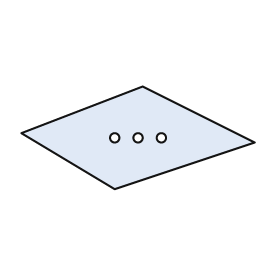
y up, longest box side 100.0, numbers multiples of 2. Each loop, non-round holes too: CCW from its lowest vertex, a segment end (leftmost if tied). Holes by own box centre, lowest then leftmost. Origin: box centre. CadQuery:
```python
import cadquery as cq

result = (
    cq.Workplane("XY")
    .moveTo(-10.0, -22.0)
    .lineTo(50.0, -2.0)
    .lineTo(2.0, 22.0)
    .lineTo(-50.0, 2.0)
    .close()
    .moveTo(-10.0, 0.0)
    .circle(2.0)
    .moveTo(0.0, 0.0)
    .circle(2.0)
    .moveTo(10.0, 0.0)
    .circle(2.0)
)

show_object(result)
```